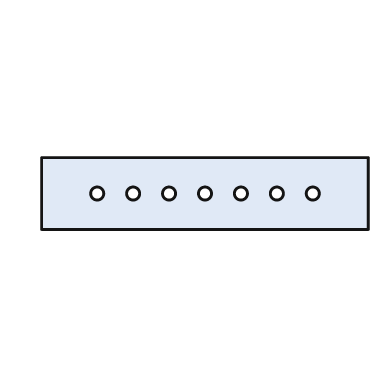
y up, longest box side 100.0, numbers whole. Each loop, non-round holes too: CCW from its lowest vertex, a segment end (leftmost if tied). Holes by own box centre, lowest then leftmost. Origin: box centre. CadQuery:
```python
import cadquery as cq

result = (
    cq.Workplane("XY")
    .moveTo(-50.0, -11.0)
    .lineTo(50.0, -11.0)
    .lineTo(50.0, 11.0)
    .lineTo(-50.0, 11.0)
    .close()
    .moveTo(-33.0, 0.0)
    .circle(2.0)
    .moveTo(-22.0, 0.0)
    .circle(2.0)
    .moveTo(-11.0, 0.0)
    .circle(2.0)
    .moveTo(0.0, 0.0)
    .circle(2.0)
    .moveTo(11.0, 0.0)
    .circle(2.0)
    .moveTo(22.0, 0.0)
    .circle(2.0)
    .moveTo(33.0, 0.0)
    .circle(2.0)
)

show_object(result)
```